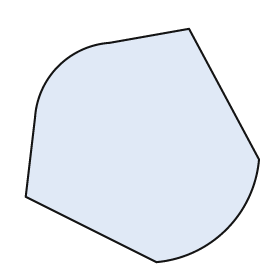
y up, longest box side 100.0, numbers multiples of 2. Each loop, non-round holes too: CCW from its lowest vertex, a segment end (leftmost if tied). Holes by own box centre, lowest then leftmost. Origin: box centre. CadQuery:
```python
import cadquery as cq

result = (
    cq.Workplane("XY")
    .moveTo(6.0, -50.0)
    .threePointArc((36.0, -36.0), (50.0, -6.0))
    .lineTo(20.0, 50.0)
    .lineTo(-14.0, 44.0)
    .threePointArc((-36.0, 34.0), (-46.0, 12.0))
    .lineTo(-50.0, -22.0)
    .close()
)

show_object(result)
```